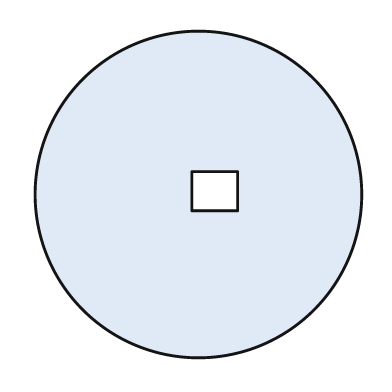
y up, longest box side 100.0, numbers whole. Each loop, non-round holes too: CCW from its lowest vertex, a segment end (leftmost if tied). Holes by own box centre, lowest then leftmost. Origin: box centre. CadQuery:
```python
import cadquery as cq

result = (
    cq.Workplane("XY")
    .moveTo(0.0, 0.0)
    .circle(50.0)
    .moveTo(-2.0, -5.0)
    .lineTo(12.0, -5.0)
    .lineTo(12.0, 7.0)
    .lineTo(-2.0, 7.0)
    .close()
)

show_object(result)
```